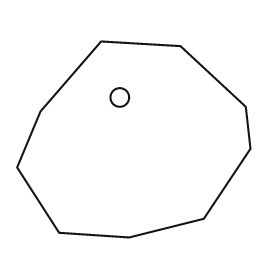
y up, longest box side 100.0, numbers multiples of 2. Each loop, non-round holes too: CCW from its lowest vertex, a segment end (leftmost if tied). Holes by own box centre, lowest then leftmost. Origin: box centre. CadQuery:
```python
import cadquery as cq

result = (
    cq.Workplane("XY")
    .moveTo(-2.0, -42.0)
    .lineTo(30.0, -34.0)
    .lineTo(50.0, -4.0)
    .lineTo(48.0, 14.0)
    .lineTo(20.0, 40.0)
    .lineTo(-14.0, 42.0)
    .lineTo(-40.0, 12.0)
    .lineTo(-50.0, -12.0)
    .lineTo(-32.0, -40.0)
    .close()
    .moveTo(-6.0, 18.0)
    .circle(4.0)
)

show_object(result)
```